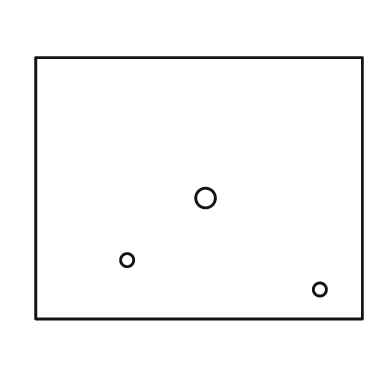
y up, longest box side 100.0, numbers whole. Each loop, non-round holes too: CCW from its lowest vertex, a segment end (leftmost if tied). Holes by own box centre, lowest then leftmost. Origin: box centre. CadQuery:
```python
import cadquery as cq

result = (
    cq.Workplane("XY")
    .moveTo(-50.0, -40.0)
    .lineTo(50.0, -40.0)
    .lineTo(50.0, 40.0)
    .lineTo(-50.0, 40.0)
    .close()
    .moveTo(37.0, -31.0)
    .circle(2.0)
    .moveTo(-22.0, -22.0)
    .circle(2.0)
    .moveTo(2.0, -3.0)
    .circle(3.0)
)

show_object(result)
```